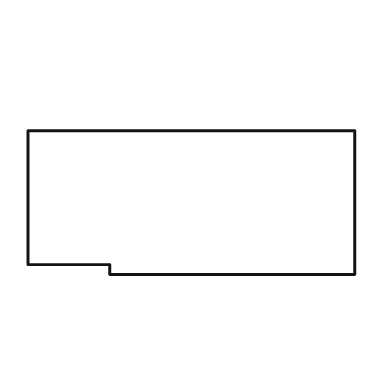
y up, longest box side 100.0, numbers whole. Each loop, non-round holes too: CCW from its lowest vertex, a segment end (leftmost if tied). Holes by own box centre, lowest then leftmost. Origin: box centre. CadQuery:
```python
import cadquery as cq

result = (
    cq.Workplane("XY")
    .moveTo(-25.0, -22.0)
    .lineTo(50.0, -22.0)
    .lineTo(50.0, 22.0)
    .lineTo(-50.0, 22.0)
    .lineTo(-50.0, -19.0)
    .lineTo(-25.0, -19.0)
    .close()
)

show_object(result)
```